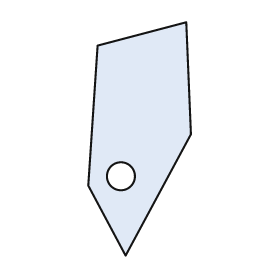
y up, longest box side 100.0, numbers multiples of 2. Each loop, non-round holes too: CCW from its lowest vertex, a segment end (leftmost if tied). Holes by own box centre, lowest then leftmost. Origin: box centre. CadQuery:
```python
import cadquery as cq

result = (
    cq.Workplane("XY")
    .moveTo(-6.0, -50.0)
    .lineTo(22.0, 2.0)
    .lineTo(20.0, 50.0)
    .lineTo(-18.0, 40.0)
    .lineTo(-22.0, -20.0)
    .close()
    .moveTo(-8.0, -16.0)
    .circle(6.0)
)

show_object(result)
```